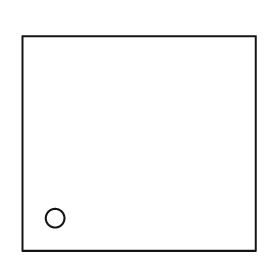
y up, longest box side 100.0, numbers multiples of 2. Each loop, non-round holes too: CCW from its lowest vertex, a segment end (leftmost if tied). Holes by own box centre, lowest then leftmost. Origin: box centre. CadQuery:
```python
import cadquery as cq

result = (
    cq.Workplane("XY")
    .moveTo(-50.0, -46.0)
    .lineTo(50.0, -46.0)
    .lineTo(50.0, 46.0)
    .lineTo(-50.0, 46.0)
    .close()
    .moveTo(-36.0, -32.0)
    .circle(4.0)
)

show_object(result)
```